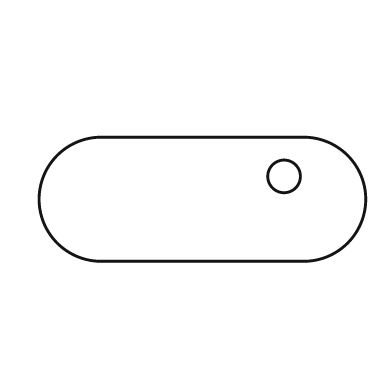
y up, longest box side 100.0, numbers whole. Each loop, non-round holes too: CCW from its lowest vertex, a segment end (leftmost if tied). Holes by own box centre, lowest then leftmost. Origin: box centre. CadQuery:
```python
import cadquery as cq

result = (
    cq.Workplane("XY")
    .moveTo(-31.0, -19.0)
    .lineTo(31.0, -19.0)
    .threePointArc((50.0, 0.0), (31.0, 19.0))
    .lineTo(-31.0, 19.0)
    .threePointArc((-50.0, 0.0), (-31.0, -19.0))
    .close()
    .moveTo(25.0, 7.0)
    .circle(5.0)
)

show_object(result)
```